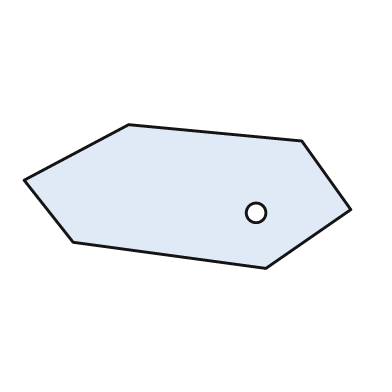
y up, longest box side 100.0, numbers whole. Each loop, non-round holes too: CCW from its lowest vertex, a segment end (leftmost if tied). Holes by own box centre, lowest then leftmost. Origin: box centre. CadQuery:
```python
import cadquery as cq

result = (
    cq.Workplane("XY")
    .moveTo(24.0, -22.0)
    .lineTo(50.0, -4.0)
    .lineTo(35.0, 17.0)
    .lineTo(-18.0, 22.0)
    .lineTo(-50.0, 5.0)
    .lineTo(-35.0, -14.0)
    .close()
    .moveTo(21.0, -5.0)
    .circle(3.0)
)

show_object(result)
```